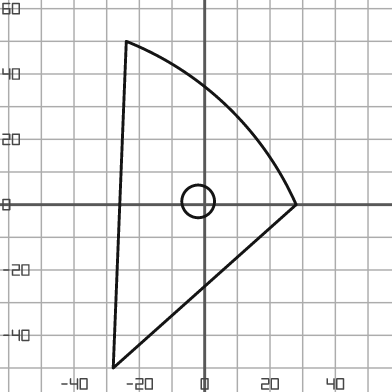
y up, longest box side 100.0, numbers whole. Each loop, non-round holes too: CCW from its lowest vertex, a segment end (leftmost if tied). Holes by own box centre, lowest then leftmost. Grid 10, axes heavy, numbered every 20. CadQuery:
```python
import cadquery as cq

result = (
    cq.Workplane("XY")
    .moveTo(-28.0, -50.0)
    .lineTo(28.0, 0.0)
    .threePointArc((7.0, 30.0), (-24.0, 50.0))
    .close()
    .moveTo(-2.0, 1.0)
    .circle(5.0)
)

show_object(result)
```